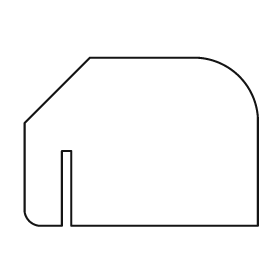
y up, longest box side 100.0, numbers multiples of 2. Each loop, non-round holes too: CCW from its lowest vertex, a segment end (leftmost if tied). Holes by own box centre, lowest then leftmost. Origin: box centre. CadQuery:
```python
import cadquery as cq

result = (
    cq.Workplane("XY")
    .moveTo(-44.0, -36.0)
    .lineTo(-34.0, -36.0)
    .lineTo(-34.0, -4.0)
    .lineTo(-30.0, -4.0)
    .lineTo(-30.0, -36.0)
    .lineTo(50.0, -36.0)
    .lineTo(50.0, 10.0)
    .threePointArc((42.0, 28.0), (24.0, 36.0))
    .lineTo(-22.0, 36.0)
    .lineTo(-50.0, 8.0)
    .lineTo(-50.0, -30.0)
    .threePointArc((-48.0, -34.0), (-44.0, -36.0))
    .close()
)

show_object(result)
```